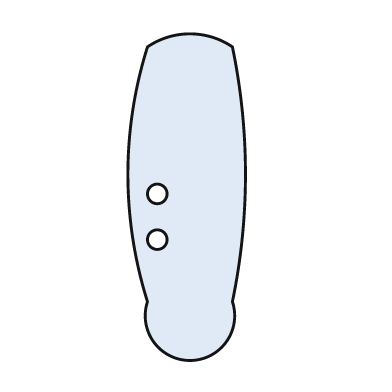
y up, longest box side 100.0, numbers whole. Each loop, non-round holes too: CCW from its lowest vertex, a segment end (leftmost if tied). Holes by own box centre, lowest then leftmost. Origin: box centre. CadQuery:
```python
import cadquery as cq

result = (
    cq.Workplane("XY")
    .moveTo(-12.0, -32.0)
    .threePointArc((1.0, -50.0), (14.0, -32.0))
    .threePointArc((18.0, 7.0), (14.0, 46.0))
    .threePointArc((1.0, 50.0), (-12.0, 46.0))
    .threePointArc((-18.0, 7.0), (-12.0, -32.0))
    .close()
    .moveTo(-9.0, -13.0)
    .circle(3.0)
    .moveTo(-9.0, 1.0)
    .circle(3.0)
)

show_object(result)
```